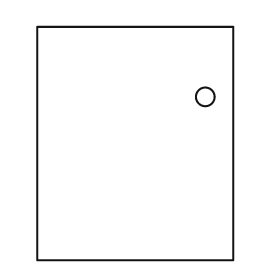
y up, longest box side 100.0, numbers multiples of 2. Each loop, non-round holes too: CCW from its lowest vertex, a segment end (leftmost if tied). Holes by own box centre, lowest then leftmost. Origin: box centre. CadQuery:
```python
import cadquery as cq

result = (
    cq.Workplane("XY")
    .moveTo(-42.0, -50.0)
    .lineTo(42.0, -50.0)
    .lineTo(42.0, 50.0)
    .lineTo(-42.0, 50.0)
    .close()
    .moveTo(30.0, 20.0)
    .circle(4.0)
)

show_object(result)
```